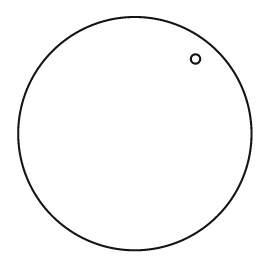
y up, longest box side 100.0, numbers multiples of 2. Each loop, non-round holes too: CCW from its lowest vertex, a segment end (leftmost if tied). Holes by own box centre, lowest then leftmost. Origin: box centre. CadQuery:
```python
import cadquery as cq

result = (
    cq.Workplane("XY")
    .moveTo(0.0, 0.0)
    .circle(50.0)
    .moveTo(26.0, 32.0)
    .circle(2.0)
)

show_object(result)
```